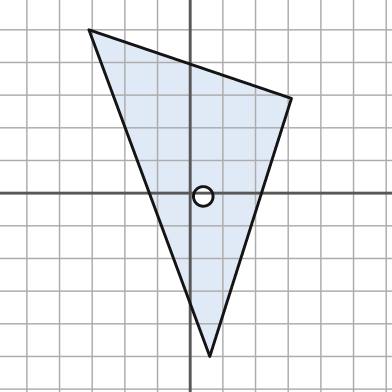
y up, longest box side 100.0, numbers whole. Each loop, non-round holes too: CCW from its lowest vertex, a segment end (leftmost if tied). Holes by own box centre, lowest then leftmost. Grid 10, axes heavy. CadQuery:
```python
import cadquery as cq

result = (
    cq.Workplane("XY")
    .moveTo(6.0, -50.0)
    .lineTo(31.0, 29.0)
    .lineTo(-31.0, 50.0)
    .close()
    .moveTo(4.0, -1.0)
    .circle(3.0)
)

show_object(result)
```